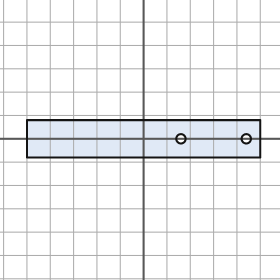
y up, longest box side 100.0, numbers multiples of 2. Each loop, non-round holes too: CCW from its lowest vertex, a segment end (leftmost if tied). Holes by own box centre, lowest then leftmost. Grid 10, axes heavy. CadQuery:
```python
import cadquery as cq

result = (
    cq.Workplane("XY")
    .moveTo(-50.0, -8.0)
    .lineTo(50.0, -8.0)
    .lineTo(50.0, 8.0)
    .lineTo(-50.0, 8.0)
    .close()
    .moveTo(16.0, 0.0)
    .circle(2.0)
    .moveTo(44.0, 0.0)
    .circle(2.0)
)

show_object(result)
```